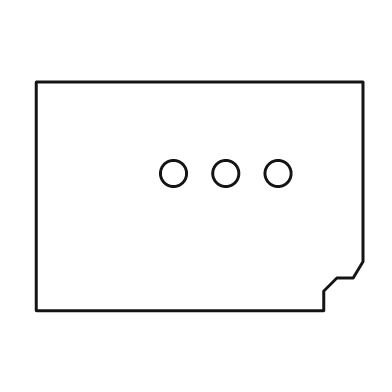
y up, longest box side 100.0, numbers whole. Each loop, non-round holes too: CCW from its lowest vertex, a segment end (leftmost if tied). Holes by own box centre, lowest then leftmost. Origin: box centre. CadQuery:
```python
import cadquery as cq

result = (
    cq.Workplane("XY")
    .moveTo(-50.0, -35.0)
    .lineTo(38.0, -35.0)
    .lineTo(38.0, -29.0)
    .lineTo(42.0, -25.0)
    .lineTo(47.0, -25.0)
    .lineTo(50.0, -20.0)
    .lineTo(50.0, 35.0)
    .lineTo(-50.0, 35.0)
    .close()
    .moveTo(-8.0, 7.0)
    .circle(4.0)
    .moveTo(8.0, 7.0)
    .circle(4.0)
    .moveTo(24.0, 7.0)
    .circle(4.0)
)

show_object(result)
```